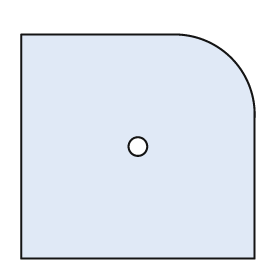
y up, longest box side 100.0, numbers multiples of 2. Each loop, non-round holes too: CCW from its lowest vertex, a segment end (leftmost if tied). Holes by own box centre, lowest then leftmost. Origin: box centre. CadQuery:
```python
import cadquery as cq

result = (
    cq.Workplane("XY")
    .moveTo(-50.0, -48.0)
    .lineTo(50.0, -48.0)
    .lineTo(50.0, 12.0)
    .threePointArc((40.0, 38.0), (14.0, 48.0))
    .lineTo(-50.0, 48.0)
    .close()
    .moveTo(0.0, 0.0)
    .circle(4.0)
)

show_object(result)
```